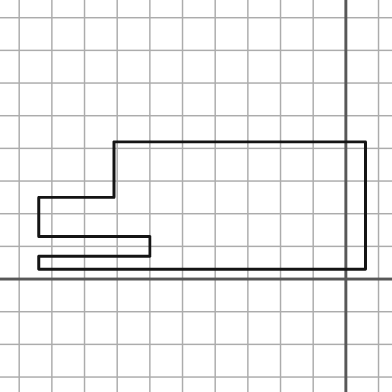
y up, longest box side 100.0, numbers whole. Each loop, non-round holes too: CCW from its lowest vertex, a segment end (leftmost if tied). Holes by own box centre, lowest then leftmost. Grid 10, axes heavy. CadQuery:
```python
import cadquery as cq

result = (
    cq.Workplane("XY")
    .moveTo(-94.0, 3.0)
    .lineTo(6.0, 3.0)
    .lineTo(6.0, 42.0)
    .lineTo(-71.0, 42.0)
    .lineTo(-71.0, 25.0)
    .lineTo(-94.0, 25.0)
    .lineTo(-94.0, 13.0)
    .lineTo(-60.0, 13.0)
    .lineTo(-60.0, 7.0)
    .lineTo(-94.0, 7.0)
    .close()
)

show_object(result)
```